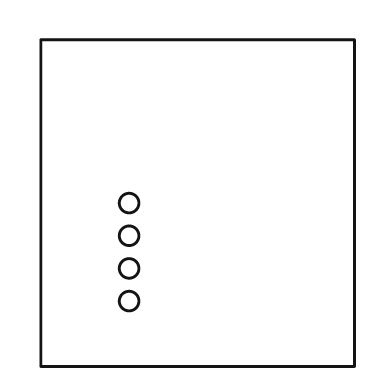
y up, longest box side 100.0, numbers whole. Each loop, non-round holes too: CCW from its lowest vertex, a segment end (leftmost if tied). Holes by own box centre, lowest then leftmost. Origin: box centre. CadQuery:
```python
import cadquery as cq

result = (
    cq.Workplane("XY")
    .moveTo(-48.0, -50.0)
    .lineTo(48.0, -50.0)
    .lineTo(48.0, 50.0)
    .lineTo(-48.0, 50.0)
    .close()
    .moveTo(-21.0, -30.0)
    .circle(3.0)
    .moveTo(-21.0, -20.0)
    .circle(3.0)
    .moveTo(-21.0, -10.0)
    .circle(3.0)
    .moveTo(-21.0, 0.0)
    .circle(3.0)
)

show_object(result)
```